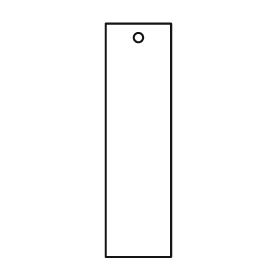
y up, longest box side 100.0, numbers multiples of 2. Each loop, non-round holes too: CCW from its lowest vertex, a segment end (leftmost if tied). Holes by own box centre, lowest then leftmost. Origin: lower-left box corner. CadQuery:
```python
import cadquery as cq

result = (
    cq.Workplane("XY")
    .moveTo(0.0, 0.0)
    .lineTo(28.0, 0.0)
    .lineTo(28.0, 100.0)
    .lineTo(0.0, 100.0)
    .close()
    .moveTo(14.0, 94.0)
    .circle(2.0)
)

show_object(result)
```